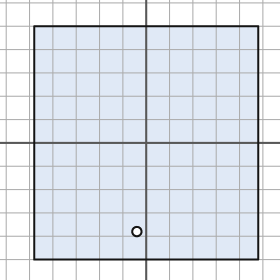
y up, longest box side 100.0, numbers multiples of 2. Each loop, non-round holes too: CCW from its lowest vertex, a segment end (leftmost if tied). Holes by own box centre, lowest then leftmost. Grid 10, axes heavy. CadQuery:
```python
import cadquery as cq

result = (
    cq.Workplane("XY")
    .moveTo(-48.0, -50.0)
    .lineTo(48.0, -50.0)
    .lineTo(48.0, 50.0)
    .lineTo(-48.0, 50.0)
    .close()
    .moveTo(-4.0, -38.0)
    .circle(2.0)
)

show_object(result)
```